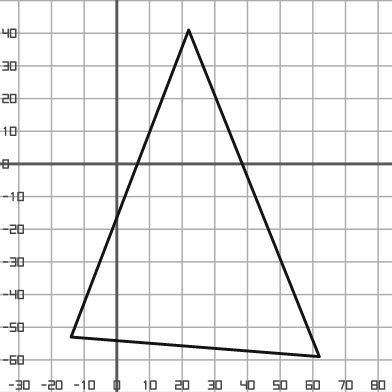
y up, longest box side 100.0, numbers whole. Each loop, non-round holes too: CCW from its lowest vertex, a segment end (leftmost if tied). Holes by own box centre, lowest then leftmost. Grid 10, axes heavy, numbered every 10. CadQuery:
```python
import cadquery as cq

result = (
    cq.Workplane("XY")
    .moveTo(62.0, -59.0)
    .lineTo(22.0, 41.0)
    .lineTo(-14.0, -53.0)
    .close()
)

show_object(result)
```